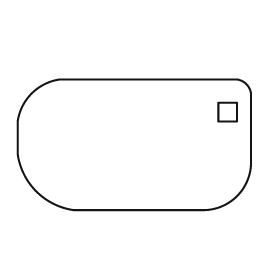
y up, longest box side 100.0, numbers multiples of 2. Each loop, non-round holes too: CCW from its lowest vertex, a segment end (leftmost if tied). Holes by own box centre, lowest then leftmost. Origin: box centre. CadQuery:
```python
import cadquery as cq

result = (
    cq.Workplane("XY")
    .moveTo(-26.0, -28.0)
    .lineTo(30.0, -28.0)
    .threePointArc((44.0, -22.0), (50.0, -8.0))
    .lineTo(50.0, 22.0)
    .threePointArc((48.0, 26.0), (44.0, 28.0))
    .lineTo(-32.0, 28.0)
    .threePointArc((-44.0, 22.0), (-50.0, 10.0))
    .lineTo(-50.0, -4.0)
    .threePointArc((-42.0, -20.0), (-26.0, -28.0))
    .close()
    .moveTo(36.0, 10.0)
    .lineTo(44.0, 10.0)
    .lineTo(44.0, 18.0)
    .lineTo(36.0, 18.0)
    .close()
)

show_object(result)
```